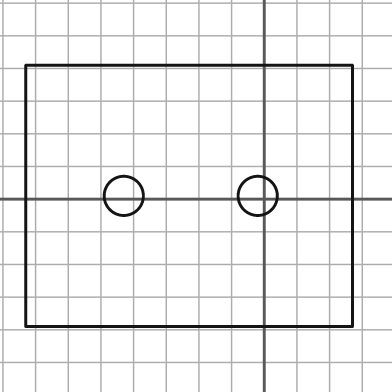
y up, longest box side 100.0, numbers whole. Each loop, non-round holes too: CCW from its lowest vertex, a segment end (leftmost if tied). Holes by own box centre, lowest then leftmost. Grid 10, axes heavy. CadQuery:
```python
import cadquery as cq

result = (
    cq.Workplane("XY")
    .moveTo(-73.0, -39.0)
    .lineTo(27.0, -39.0)
    .lineTo(27.0, 41.0)
    .lineTo(-73.0, 41.0)
    .close()
    .moveTo(-43.0, 1.0)
    .circle(6.0)
    .moveTo(-2.0, 1.0)
    .circle(6.0)
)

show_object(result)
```